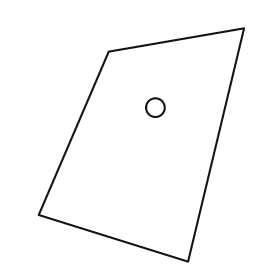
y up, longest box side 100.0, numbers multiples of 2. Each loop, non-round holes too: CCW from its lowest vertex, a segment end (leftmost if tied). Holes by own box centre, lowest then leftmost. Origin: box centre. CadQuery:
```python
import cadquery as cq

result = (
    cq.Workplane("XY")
    .moveTo(20.0, -50.0)
    .lineTo(44.0, 50.0)
    .lineTo(-14.0, 40.0)
    .lineTo(-44.0, -30.0)
    .close()
    .moveTo(6.0, 16.0)
    .circle(4.0)
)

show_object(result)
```